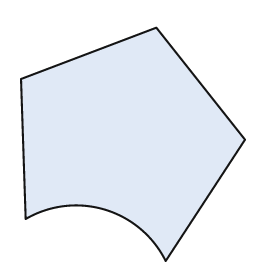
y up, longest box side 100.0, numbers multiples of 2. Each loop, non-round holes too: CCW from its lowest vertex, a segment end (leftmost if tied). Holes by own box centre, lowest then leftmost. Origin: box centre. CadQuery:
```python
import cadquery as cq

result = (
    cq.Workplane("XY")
    .moveTo(14.0, -50.0)
    .lineTo(48.0, 2.0)
    .lineTo(10.0, 50.0)
    .lineTo(-48.0, 28.0)
    .lineTo(-46.0, -32.0)
    .threePointArc((-12.0, -28.0), (14.0, -50.0))
    .close()
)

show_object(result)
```